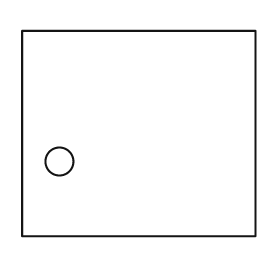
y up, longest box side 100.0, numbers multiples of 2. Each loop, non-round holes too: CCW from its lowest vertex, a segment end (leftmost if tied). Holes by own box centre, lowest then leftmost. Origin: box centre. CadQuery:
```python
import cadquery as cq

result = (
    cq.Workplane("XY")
    .moveTo(-50.0, -44.0)
    .lineTo(50.0, -44.0)
    .lineTo(50.0, 44.0)
    .lineTo(-50.0, 44.0)
    .close()
    .moveTo(-34.0, -12.0)
    .circle(6.0)
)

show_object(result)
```